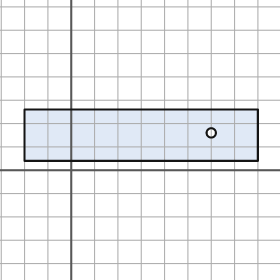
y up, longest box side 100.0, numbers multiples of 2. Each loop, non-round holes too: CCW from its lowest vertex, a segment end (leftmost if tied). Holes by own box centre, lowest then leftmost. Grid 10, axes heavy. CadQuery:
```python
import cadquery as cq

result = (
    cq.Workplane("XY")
    .moveTo(-20.0, 4.0)
    .lineTo(80.0, 4.0)
    .lineTo(80.0, 26.0)
    .lineTo(-20.0, 26.0)
    .close()
    .moveTo(60.0, 16.0)
    .circle(2.0)
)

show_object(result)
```